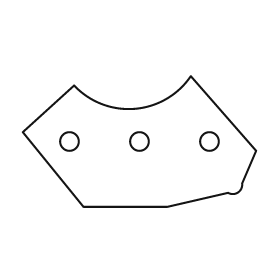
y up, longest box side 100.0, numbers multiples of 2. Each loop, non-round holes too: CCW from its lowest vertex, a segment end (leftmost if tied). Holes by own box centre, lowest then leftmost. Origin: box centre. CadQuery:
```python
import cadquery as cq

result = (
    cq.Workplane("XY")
    .moveTo(-24.0, -28.0)
    .lineTo(12.0, -28.0)
    .lineTo(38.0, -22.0)
    .threePointArc((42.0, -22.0), (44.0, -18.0))
    .lineTo(50.0, -4.0)
    .lineTo(22.0, 28.0)
    .threePointArc((-2.0, 14.0), (-28.0, 24.0))
    .lineTo(-50.0, 4.0)
    .close()
    .moveTo(-30.0, 0.0)
    .circle(4.0)
    .moveTo(0.0, 0.0)
    .circle(4.0)
    .moveTo(30.0, 0.0)
    .circle(4.0)
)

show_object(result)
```